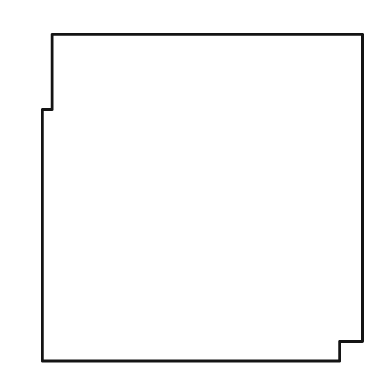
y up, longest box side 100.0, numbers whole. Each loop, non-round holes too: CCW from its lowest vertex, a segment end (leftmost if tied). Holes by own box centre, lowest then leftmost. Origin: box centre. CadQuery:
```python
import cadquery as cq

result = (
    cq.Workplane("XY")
    .moveTo(-49.0, -50.0)
    .lineTo(42.0, -50.0)
    .lineTo(42.0, -44.0)
    .lineTo(49.0, -44.0)
    .lineTo(49.0, 50.0)
    .lineTo(-46.0, 50.0)
    .lineTo(-46.0, 27.0)
    .lineTo(-49.0, 27.0)
    .close()
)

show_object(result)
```